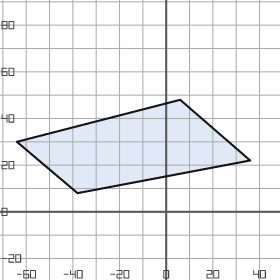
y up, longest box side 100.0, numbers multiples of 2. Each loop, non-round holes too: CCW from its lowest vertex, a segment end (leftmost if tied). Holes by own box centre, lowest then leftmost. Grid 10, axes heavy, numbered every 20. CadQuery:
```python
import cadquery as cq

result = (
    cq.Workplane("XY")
    .moveTo(-38.0, 8.0)
    .lineTo(36.0, 22.0)
    .lineTo(6.0, 48.0)
    .lineTo(-64.0, 30.0)
    .close()
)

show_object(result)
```